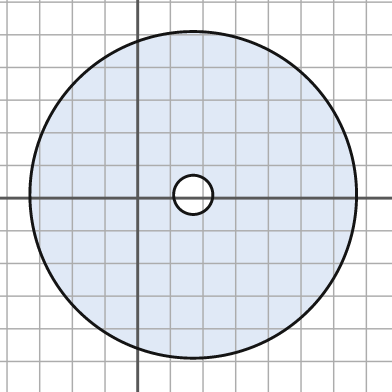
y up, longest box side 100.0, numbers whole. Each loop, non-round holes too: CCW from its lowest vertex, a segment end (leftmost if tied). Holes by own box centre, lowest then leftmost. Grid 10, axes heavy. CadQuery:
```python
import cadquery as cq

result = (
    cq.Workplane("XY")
    .moveTo(17.0, 1.0)
    .circle(50.0)
    .moveTo(17.0, 1.0)
    .circle(6.0)
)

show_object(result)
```